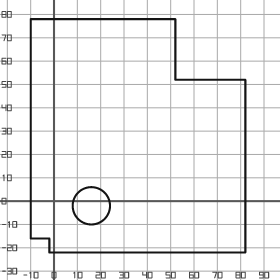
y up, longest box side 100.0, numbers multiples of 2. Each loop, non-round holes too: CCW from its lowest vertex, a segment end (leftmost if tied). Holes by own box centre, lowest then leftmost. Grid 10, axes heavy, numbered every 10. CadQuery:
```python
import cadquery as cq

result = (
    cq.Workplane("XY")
    .moveTo(-2.0, -22.0)
    .lineTo(82.0, -22.0)
    .lineTo(82.0, 52.0)
    .lineTo(52.0, 52.0)
    .lineTo(52.0, 78.0)
    .lineTo(-10.0, 78.0)
    .lineTo(-10.0, -16.0)
    .lineTo(-2.0, -16.0)
    .close()
    .moveTo(16.0, -2.0)
    .circle(8.0)
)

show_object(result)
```